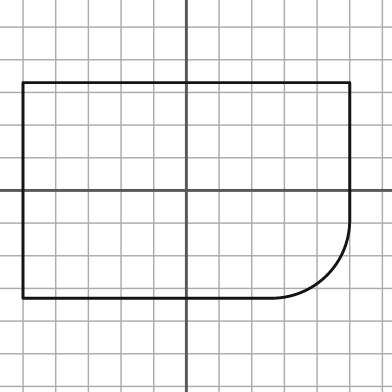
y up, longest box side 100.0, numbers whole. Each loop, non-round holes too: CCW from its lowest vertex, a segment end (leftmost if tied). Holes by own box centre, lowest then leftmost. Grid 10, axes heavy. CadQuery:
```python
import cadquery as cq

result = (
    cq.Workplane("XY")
    .moveTo(-50.0, -33.0)
    .lineTo(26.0, -33.0)
    .threePointArc((43.0, -26.0), (50.0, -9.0))
    .lineTo(50.0, 33.0)
    .lineTo(-50.0, 33.0)
    .close()
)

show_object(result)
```